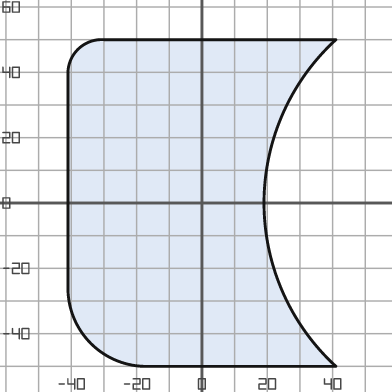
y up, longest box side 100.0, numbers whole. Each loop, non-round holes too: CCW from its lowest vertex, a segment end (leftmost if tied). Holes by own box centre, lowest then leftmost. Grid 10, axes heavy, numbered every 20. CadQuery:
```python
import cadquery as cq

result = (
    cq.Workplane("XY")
    .moveTo(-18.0, -50.0)
    .lineTo(41.0, -50.0)
    .threePointArc((19.0, 0.0), (41.0, 50.0))
    .lineTo(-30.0, 50.0)
    .threePointArc((-38.0, 47.0), (-41.0, 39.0))
    .lineTo(-41.0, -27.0)
    .threePointArc((-34.0, -43.0), (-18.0, -50.0))
    .close()
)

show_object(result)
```